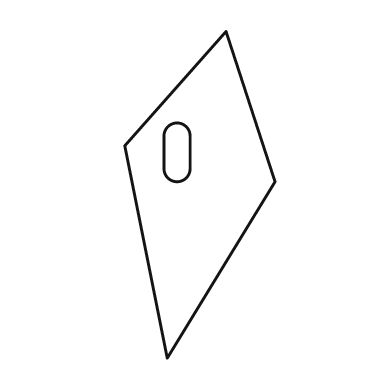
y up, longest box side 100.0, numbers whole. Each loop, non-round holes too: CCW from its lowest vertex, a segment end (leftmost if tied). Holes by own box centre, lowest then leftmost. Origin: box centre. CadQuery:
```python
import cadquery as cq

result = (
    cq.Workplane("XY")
    .moveTo(-10.0, -50.0)
    .lineTo(23.0, 4.0)
    .lineTo(8.0, 50.0)
    .lineTo(-23.0, 15.0)
    .close()
    .moveTo(-11.0, 8.0)
    .threePointArc((-7.0, 4.0), (-3.0, 8.0))
    .lineTo(-3.0, 18.0)
    .threePointArc((-7.0, 22.0), (-11.0, 18.0))
    .close()
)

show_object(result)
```